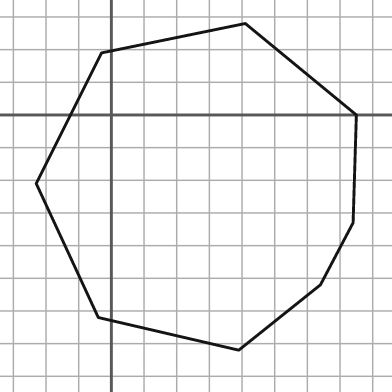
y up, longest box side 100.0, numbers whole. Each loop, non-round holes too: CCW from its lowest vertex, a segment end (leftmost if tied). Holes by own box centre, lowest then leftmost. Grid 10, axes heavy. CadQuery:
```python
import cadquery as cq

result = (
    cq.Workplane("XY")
    .moveTo(39.0, -72.0)
    .lineTo(64.0, -52.0)
    .lineTo(74.0, -33.0)
    .lineTo(75.0, 0.0)
    .lineTo(41.0, 28.0)
    .lineTo(-3.0, 19.0)
    .lineTo(-23.0, -21.0)
    .lineTo(-4.0, -62.0)
    .close()
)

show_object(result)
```